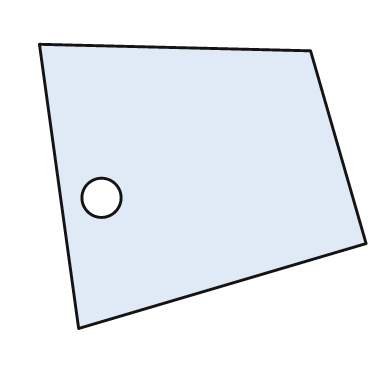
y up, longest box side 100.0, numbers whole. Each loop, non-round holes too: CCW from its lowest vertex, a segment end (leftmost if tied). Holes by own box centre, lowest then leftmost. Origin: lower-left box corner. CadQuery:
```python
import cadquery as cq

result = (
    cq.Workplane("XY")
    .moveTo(12.0, 0.0)
    .lineTo(100.0, 26.0)
    .lineTo(83.0, 85.0)
    .lineTo(0.0, 87.0)
    .close()
    .moveTo(19.0, 40.0)
    .circle(6.0)
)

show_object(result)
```